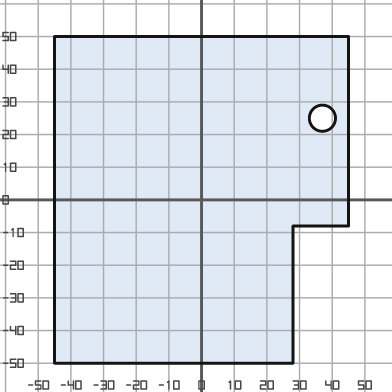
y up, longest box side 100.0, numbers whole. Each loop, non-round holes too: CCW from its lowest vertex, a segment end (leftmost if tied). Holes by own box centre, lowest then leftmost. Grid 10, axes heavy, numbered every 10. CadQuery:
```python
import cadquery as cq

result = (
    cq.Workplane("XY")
    .moveTo(-45.0, -50.0)
    .lineTo(28.0, -50.0)
    .lineTo(28.0, -8.0)
    .lineTo(45.0, -8.0)
    .lineTo(45.0, 50.0)
    .lineTo(-45.0, 50.0)
    .close()
    .moveTo(37.0, 25.0)
    .circle(4.0)
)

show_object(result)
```